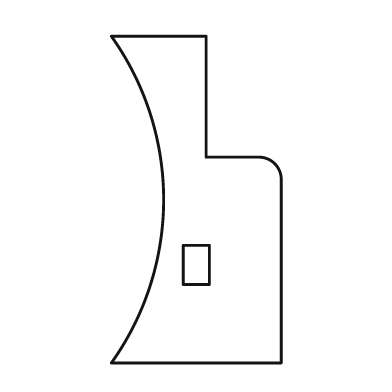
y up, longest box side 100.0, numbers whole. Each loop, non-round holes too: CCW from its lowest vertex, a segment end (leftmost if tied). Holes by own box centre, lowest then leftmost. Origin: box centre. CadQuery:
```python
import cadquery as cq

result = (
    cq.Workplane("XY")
    .moveTo(-26.0, -50.0)
    .lineTo(26.0, -50.0)
    .lineTo(26.0, 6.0)
    .threePointArc((24.0, 11.0), (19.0, 13.0))
    .lineTo(3.0, 13.0)
    .lineTo(3.0, 50.0)
    .lineTo(-26.0, 50.0)
    .threePointArc((-10.0, 0.0), (-26.0, -50.0))
    .close()
    .moveTo(-4.0, -26.0)
    .lineTo(4.0, -26.0)
    .lineTo(4.0, -14.0)
    .lineTo(-4.0, -14.0)
    .close()
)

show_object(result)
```